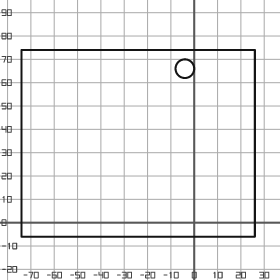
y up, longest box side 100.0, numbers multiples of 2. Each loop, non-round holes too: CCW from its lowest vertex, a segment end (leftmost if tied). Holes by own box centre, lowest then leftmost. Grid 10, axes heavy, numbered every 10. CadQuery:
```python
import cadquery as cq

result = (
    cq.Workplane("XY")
    .moveTo(-74.0, -6.0)
    .lineTo(26.0, -6.0)
    .lineTo(26.0, 74.0)
    .lineTo(-74.0, 74.0)
    .close()
    .moveTo(-4.0, 66.0)
    .circle(4.0)
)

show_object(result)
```